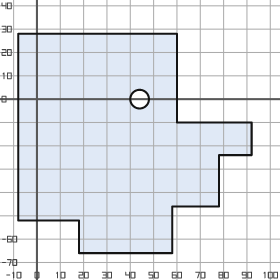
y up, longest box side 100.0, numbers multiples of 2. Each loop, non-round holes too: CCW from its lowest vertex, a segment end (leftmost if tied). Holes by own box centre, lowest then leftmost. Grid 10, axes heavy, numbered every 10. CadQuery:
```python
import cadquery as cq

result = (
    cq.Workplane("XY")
    .moveTo(18.0, -66.0)
    .lineTo(58.0, -66.0)
    .lineTo(58.0, -46.0)
    .lineTo(78.0, -46.0)
    .lineTo(78.0, -24.0)
    .lineTo(92.0, -24.0)
    .lineTo(92.0, -10.0)
    .lineTo(60.0, -10.0)
    .lineTo(60.0, 28.0)
    .lineTo(-8.0, 28.0)
    .lineTo(-8.0, -52.0)
    .lineTo(18.0, -52.0)
    .close()
    .moveTo(44.0, 0.0)
    .circle(4.0)
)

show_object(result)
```